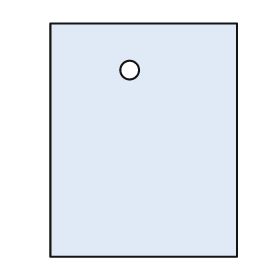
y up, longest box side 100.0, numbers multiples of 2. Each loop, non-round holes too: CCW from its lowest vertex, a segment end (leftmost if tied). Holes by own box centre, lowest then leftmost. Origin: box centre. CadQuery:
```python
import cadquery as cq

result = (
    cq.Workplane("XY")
    .moveTo(-40.0, -50.0)
    .lineTo(40.0, -50.0)
    .lineTo(40.0, 50.0)
    .lineTo(-40.0, 50.0)
    .close()
    .moveTo(-6.0, 30.0)
    .circle(4.0)
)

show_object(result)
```